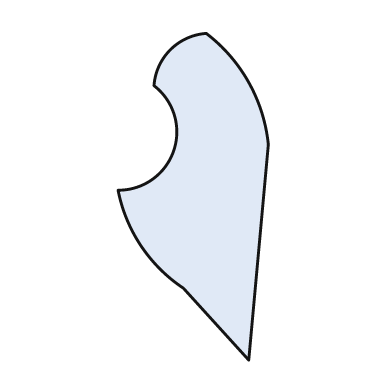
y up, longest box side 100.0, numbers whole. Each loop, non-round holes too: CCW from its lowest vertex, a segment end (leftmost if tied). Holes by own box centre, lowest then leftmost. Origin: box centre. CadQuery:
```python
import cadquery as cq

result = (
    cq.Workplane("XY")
    .moveTo(17.0, -50.0)
    .lineTo(23.0, 16.0)
    .threePointArc((17.0, 35.0), (4.0, 50.0))
    .threePointArc((-7.0, 45.0), (-12.0, 34.0))
    .threePointArc((-6.0, 14.0), (-23.0, 2.0))
    .threePointArc((-16.0, -15.0), (-3.0, -28.0))
    .close()
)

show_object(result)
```